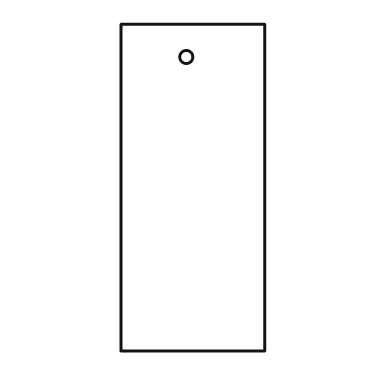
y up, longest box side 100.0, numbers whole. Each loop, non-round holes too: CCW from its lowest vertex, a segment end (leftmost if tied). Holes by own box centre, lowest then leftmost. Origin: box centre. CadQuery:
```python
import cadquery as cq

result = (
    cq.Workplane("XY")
    .moveTo(-22.0, -50.0)
    .lineTo(22.0, -50.0)
    .lineTo(22.0, 50.0)
    .lineTo(-22.0, 50.0)
    .close()
    .moveTo(-2.0, 40.0)
    .circle(2.0)
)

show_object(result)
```